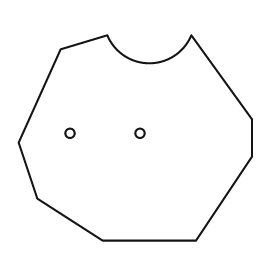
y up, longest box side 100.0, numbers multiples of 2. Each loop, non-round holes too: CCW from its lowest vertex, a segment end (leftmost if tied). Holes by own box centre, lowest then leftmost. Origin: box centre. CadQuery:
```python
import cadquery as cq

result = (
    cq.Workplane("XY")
    .moveTo(-14.0, -44.0)
    .lineTo(26.0, -44.0)
    .lineTo(50.0, -8.0)
    .lineTo(50.0, 8.0)
    .lineTo(24.0, 44.0)
    .threePointArc((6.0, 32.0), (-12.0, 44.0))
    .lineTo(-32.0, 38.0)
    .lineTo(-50.0, -2.0)
    .lineTo(-42.0, -26.0)
    .close()
    .moveTo(-28.0, 2.0)
    .circle(2.0)
    .moveTo(2.0, 2.0)
    .circle(2.0)
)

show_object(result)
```